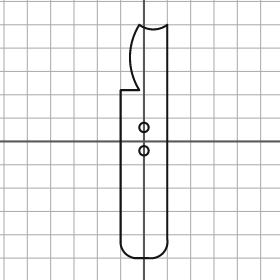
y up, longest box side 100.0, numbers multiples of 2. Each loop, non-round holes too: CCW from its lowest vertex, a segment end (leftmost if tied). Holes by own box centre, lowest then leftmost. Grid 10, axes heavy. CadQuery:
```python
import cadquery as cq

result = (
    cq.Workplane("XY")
    .moveTo(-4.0, -50.0)
    .lineTo(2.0, -50.0)
    .threePointArc((8.0, -48.0), (10.0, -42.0))
    .lineTo(10.0, 50.0)
    .threePointArc((4.0, 48.0), (-2.0, 50.0))
    .threePointArc((-6.0, 36.0), (-2.0, 22.0))
    .lineTo(-10.0, 22.0)
    .lineTo(-10.0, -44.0)
    .threePointArc((-8.0, -48.0), (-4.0, -50.0))
    .close()
    .moveTo(0.0, -4.0)
    .circle(2.0)
    .moveTo(0.0, 6.0)
    .circle(2.0)
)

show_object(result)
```